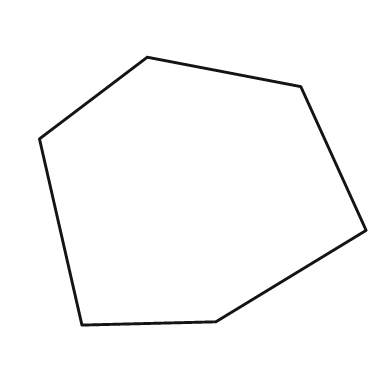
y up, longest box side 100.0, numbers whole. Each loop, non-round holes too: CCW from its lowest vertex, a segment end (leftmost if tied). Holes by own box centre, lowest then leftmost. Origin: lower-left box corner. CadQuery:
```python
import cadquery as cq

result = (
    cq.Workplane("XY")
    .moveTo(13.0, 0.0)
    .lineTo(54.0, 1.0)
    .lineTo(100.0, 29.0)
    .lineTo(80.0, 73.0)
    .lineTo(33.0, 82.0)
    .lineTo(0.0, 57.0)
    .close()
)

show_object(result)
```